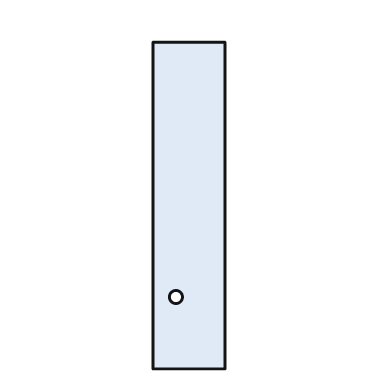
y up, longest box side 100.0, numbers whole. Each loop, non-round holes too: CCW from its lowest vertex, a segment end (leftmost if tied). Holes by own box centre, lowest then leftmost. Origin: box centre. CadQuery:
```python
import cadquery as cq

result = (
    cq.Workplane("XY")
    .moveTo(-11.0, -50.0)
    .lineTo(11.0, -50.0)
    .lineTo(11.0, 50.0)
    .lineTo(-11.0, 50.0)
    .close()
    .moveTo(-4.0, -28.0)
    .circle(2.0)
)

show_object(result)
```